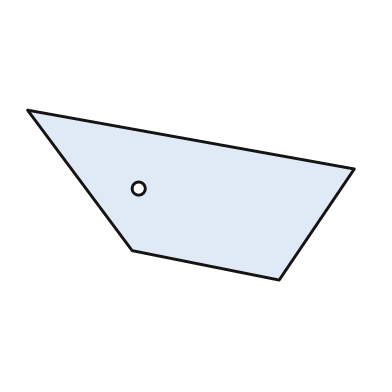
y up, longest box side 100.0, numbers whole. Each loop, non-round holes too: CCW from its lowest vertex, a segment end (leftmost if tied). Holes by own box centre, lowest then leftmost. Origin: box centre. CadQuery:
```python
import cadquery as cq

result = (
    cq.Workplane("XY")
    .moveTo(27.0, -26.0)
    .lineTo(50.0, 8.0)
    .lineTo(-50.0, 26.0)
    .lineTo(-18.0, -17.0)
    .close()
    .moveTo(-16.0, 2.0)
    .circle(2.0)
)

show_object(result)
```